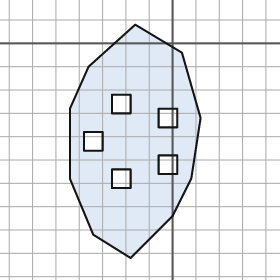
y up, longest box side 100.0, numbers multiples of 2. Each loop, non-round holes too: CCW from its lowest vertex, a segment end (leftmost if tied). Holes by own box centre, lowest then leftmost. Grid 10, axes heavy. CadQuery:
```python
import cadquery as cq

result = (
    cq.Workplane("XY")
    .moveTo(-18.0, -92.0)
    .lineTo(0.0, -74.0)
    .lineTo(8.0, -58.0)
    .lineTo(12.0, -32.0)
    .lineTo(4.0, -4.0)
    .lineTo(-16.0, 8.0)
    .lineTo(-36.0, -10.0)
    .lineTo(-44.0, -28.0)
    .lineTo(-44.0, -58.0)
    .lineTo(-34.0, -82.0)
    .close()
    .moveTo(-26.0, -62.0)
    .lineTo(-18.0, -62.0)
    .lineTo(-18.0, -54.0)
    .lineTo(-26.0, -54.0)
    .close()
    .moveTo(-6.0, -56.0)
    .lineTo(2.0, -56.0)
    .lineTo(2.0, -48.0)
    .lineTo(-6.0, -48.0)
    .close()
    .moveTo(-38.0, -46.0)
    .lineTo(-30.0, -46.0)
    .lineTo(-30.0, -38.0)
    .lineTo(-38.0, -38.0)
    .close()
    .moveTo(-6.0, -36.0)
    .lineTo(2.0, -36.0)
    .lineTo(2.0, -28.0)
    .lineTo(-6.0, -28.0)
    .close()
    .moveTo(-26.0, -30.0)
    .lineTo(-18.0, -30.0)
    .lineTo(-18.0, -22.0)
    .lineTo(-26.0, -22.0)
    .close()
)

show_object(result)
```